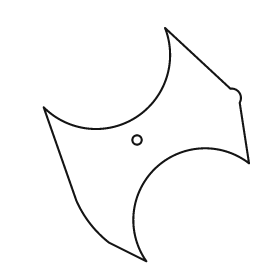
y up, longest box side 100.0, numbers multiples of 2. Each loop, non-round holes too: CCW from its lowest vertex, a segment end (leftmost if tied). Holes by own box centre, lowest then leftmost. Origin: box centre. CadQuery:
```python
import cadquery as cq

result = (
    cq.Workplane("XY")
    .moveTo(0.0, -50.0)
    .threePointArc((4.0, -10.0), (44.0, -8.0))
    .lineTo(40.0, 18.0)
    .threePointArc((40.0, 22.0), (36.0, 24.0))
    .lineTo(8.0, 50.0)
    .threePointArc((-4.0, 12.0), (-44.0, 16.0))
    .lineTo(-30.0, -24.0)
    .threePointArc((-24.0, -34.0), (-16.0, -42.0))
    .close()
    .moveTo(-4.0, 2.0)
    .circle(2.0)
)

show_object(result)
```